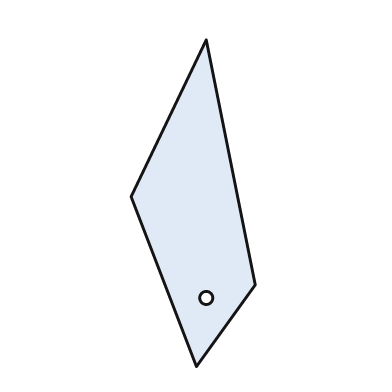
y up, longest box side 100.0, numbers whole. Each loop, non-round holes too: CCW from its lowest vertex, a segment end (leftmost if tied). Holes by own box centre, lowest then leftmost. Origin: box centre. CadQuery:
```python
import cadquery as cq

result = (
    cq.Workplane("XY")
    .moveTo(1.0, -50.0)
    .lineTo(19.0, -25.0)
    .lineTo(4.0, 50.0)
    .lineTo(-19.0, 2.0)
    .close()
    .moveTo(4.0, -29.0)
    .circle(2.0)
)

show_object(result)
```